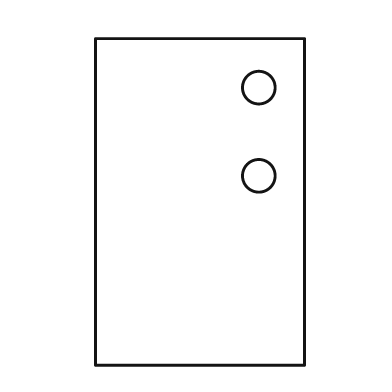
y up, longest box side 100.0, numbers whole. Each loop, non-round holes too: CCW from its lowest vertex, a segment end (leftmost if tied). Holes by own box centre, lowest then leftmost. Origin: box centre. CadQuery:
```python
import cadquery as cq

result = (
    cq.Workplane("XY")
    .moveTo(-32.0, -50.0)
    .lineTo(32.0, -50.0)
    .lineTo(32.0, 50.0)
    .lineTo(-32.0, 50.0)
    .close()
    .moveTo(18.0, 8.0)
    .circle(5.0)
    .moveTo(18.0, 35.0)
    .circle(5.0)
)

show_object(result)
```